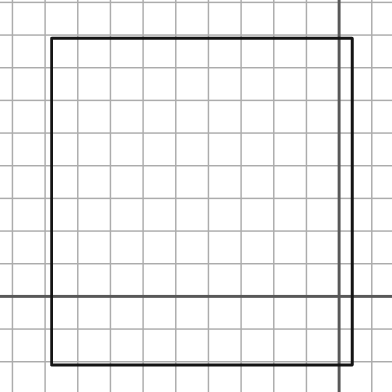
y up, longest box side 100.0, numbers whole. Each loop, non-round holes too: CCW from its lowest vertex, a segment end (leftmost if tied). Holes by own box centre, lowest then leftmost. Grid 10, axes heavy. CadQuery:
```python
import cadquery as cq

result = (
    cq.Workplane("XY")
    .moveTo(-88.0, -21.0)
    .lineTo(4.0, -21.0)
    .lineTo(4.0, 79.0)
    .lineTo(-88.0, 79.0)
    .close()
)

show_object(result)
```